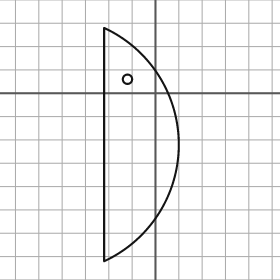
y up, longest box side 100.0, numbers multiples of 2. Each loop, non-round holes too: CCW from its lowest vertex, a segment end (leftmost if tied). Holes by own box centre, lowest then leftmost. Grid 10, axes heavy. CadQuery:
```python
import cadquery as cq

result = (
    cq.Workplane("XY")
    .moveTo(-22.0, -72.0)
    .threePointArc((10.0, -22.0), (-22.0, 28.0))
    .close()
    .moveTo(-12.0, 6.0)
    .circle(2.0)
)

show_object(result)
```